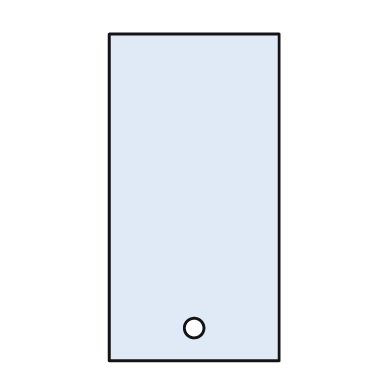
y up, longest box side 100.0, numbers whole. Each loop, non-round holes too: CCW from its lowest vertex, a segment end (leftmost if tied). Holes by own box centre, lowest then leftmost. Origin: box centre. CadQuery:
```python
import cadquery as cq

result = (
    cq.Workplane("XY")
    .moveTo(-26.0, -50.0)
    .lineTo(26.0, -50.0)
    .lineTo(26.0, 50.0)
    .lineTo(-26.0, 50.0)
    .close()
    .moveTo(0.0, -40.0)
    .circle(3.0)
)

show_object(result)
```